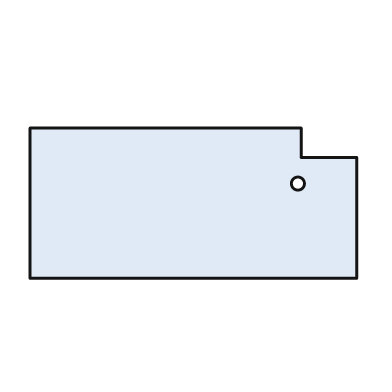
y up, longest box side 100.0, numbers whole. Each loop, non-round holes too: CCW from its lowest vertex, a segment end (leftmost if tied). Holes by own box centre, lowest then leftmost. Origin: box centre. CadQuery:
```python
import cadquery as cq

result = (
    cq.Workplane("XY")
    .moveTo(-50.0, -23.0)
    .lineTo(50.0, -23.0)
    .lineTo(50.0, 14.0)
    .lineTo(33.0, 14.0)
    .lineTo(33.0, 23.0)
    .lineTo(-50.0, 23.0)
    .close()
    .moveTo(32.0, 6.0)
    .circle(2.0)
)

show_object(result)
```